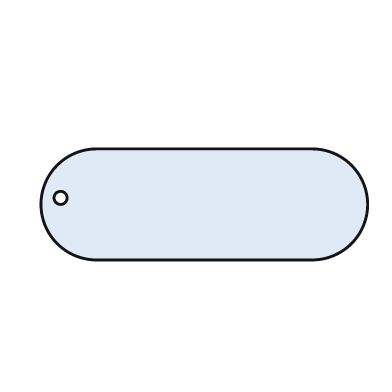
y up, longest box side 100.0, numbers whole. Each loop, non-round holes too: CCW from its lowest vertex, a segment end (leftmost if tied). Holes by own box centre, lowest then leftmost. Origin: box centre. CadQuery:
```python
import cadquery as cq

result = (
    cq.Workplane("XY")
    .moveTo(-33.0, -17.0)
    .lineTo(33.0, -17.0)
    .threePointArc((50.0, 0.0), (33.0, 17.0))
    .lineTo(-33.0, 17.0)
    .threePointArc((-50.0, 0.0), (-33.0, -17.0))
    .close()
    .moveTo(-44.0, 2.0)
    .circle(2.0)
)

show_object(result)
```